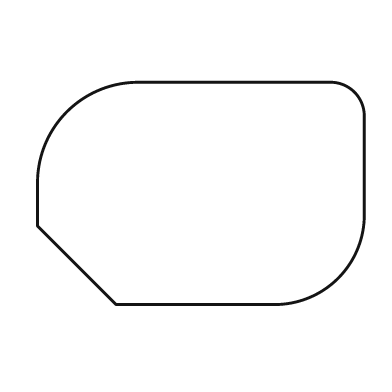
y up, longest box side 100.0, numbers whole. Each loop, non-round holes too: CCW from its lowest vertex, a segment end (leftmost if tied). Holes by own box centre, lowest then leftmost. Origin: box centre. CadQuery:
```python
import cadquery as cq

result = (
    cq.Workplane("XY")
    .moveTo(-26.0, -34.0)
    .lineTo(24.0, -34.0)
    .threePointArc((42.0, -26.0), (50.0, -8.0))
    .lineTo(50.0, 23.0)
    .threePointArc((47.0, 31.0), (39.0, 34.0))
    .lineTo(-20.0, 34.0)
    .threePointArc((-41.0, 25.0), (-50.0, 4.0))
    .lineTo(-50.0, -10.0)
    .close()
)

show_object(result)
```